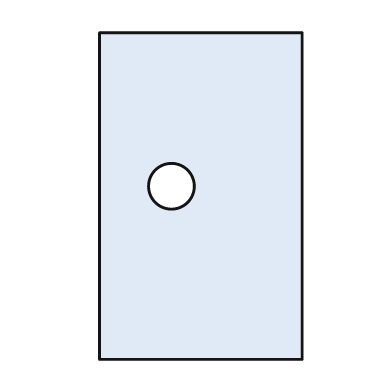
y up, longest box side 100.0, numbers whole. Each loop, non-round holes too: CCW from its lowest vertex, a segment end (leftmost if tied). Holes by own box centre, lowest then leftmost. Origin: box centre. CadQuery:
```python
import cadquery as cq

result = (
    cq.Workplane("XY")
    .moveTo(-31.0, -50.0)
    .lineTo(31.0, -50.0)
    .lineTo(31.0, 50.0)
    .lineTo(-31.0, 50.0)
    .close()
    .moveTo(-9.0, 3.0)
    .circle(7.0)
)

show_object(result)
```